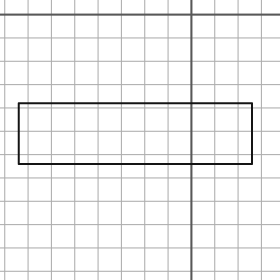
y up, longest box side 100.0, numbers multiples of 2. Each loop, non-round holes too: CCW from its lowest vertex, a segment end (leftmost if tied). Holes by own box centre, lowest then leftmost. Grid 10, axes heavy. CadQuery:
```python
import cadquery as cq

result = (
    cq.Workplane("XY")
    .moveTo(-74.0, -64.0)
    .lineTo(26.0, -64.0)
    .lineTo(26.0, -38.0)
    .lineTo(-74.0, -38.0)
    .close()
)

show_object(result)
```